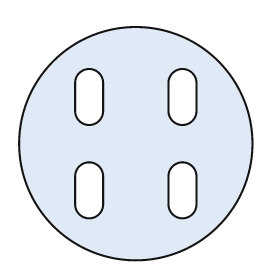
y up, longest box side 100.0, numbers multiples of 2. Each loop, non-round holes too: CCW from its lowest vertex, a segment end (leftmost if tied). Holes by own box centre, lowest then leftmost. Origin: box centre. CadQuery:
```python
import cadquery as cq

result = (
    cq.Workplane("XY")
    .moveTo(0.0, 0.0)
    .circle(50.0)
    .moveTo(-26.0, -26.0)
    .threePointArc((-20.0, -32.0), (-14.0, -26.0))
    .lineTo(-14.0, -14.0)
    .threePointArc((-20.0, -8.0), (-26.0, -14.0))
    .close()
    .moveTo(14.0, -26.0)
    .threePointArc((20.0, -32.0), (26.0, -26.0))
    .lineTo(26.0, -14.0)
    .threePointArc((20.0, -8.0), (14.0, -14.0))
    .close()
    .moveTo(-26.0, 14.0)
    .threePointArc((-20.0, 8.0), (-14.0, 14.0))
    .lineTo(-14.0, 26.0)
    .threePointArc((-20.0, 32.0), (-26.0, 26.0))
    .close()
    .moveTo(14.0, 14.0)
    .threePointArc((20.0, 8.0), (26.0, 14.0))
    .lineTo(26.0, 26.0)
    .threePointArc((20.0, 32.0), (14.0, 26.0))
    .close()
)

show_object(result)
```